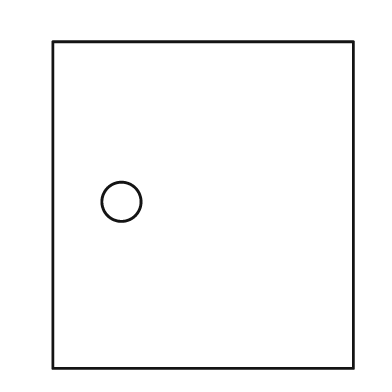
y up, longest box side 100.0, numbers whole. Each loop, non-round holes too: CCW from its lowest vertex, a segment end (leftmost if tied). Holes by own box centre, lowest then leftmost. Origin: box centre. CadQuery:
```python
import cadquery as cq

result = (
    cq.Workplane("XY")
    .moveTo(-46.0, -50.0)
    .lineTo(46.0, -50.0)
    .lineTo(46.0, 50.0)
    .lineTo(-46.0, 50.0)
    .close()
    .moveTo(-25.0, 1.0)
    .circle(6.0)
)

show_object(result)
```